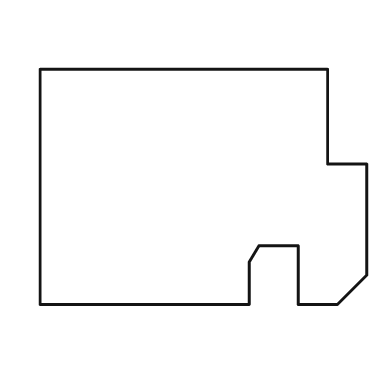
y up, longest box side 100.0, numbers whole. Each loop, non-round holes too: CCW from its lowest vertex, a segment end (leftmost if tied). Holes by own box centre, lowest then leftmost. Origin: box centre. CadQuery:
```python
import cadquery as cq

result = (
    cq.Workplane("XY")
    .moveTo(-50.0, -36.0)
    .lineTo(14.0, -36.0)
    .lineTo(14.0, -23.0)
    .lineTo(17.0, -18.0)
    .lineTo(29.0, -18.0)
    .lineTo(29.0, -36.0)
    .lineTo(41.0, -36.0)
    .lineTo(50.0, -27.0)
    .lineTo(50.0, 7.0)
    .lineTo(38.0, 7.0)
    .lineTo(38.0, 36.0)
    .lineTo(-50.0, 36.0)
    .close()
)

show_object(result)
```